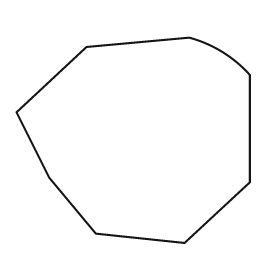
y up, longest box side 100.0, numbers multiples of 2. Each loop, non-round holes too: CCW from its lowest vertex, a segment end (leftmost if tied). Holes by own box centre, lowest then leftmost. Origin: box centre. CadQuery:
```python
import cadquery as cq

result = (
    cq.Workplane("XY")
    .moveTo(22.0, -44.0)
    .lineTo(50.0, -18.0)
    .lineTo(50.0, 28.0)
    .threePointArc((38.0, 38.0), (24.0, 44.0))
    .lineTo(-20.0, 40.0)
    .lineTo(-50.0, 12.0)
    .lineTo(-36.0, -16.0)
    .lineTo(-16.0, -40.0)
    .close()
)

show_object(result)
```